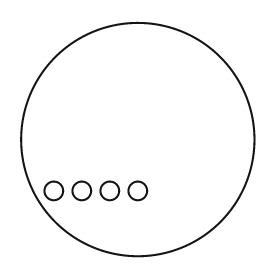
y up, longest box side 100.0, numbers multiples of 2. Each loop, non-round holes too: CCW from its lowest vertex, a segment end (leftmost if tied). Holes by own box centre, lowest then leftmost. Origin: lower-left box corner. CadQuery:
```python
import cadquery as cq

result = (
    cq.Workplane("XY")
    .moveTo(50.0, 50.0)
    .circle(50.0)
    .moveTo(14.0, 28.0)
    .circle(4.0)
    .moveTo(26.0, 28.0)
    .circle(4.0)
    .moveTo(38.0, 28.0)
    .circle(4.0)
    .moveTo(50.0, 28.0)
    .circle(4.0)
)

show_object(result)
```